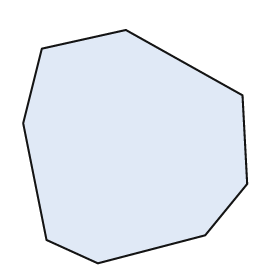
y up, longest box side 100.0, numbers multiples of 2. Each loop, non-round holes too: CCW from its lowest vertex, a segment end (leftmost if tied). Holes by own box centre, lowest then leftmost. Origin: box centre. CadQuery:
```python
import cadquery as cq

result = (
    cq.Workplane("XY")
    .moveTo(-16.0, -50.0)
    .lineTo(30.0, -38.0)
    .lineTo(48.0, -16.0)
    .lineTo(46.0, 22.0)
    .lineTo(-4.0, 50.0)
    .lineTo(-40.0, 42.0)
    .lineTo(-48.0, 10.0)
    .lineTo(-38.0, -40.0)
    .close()
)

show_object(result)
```